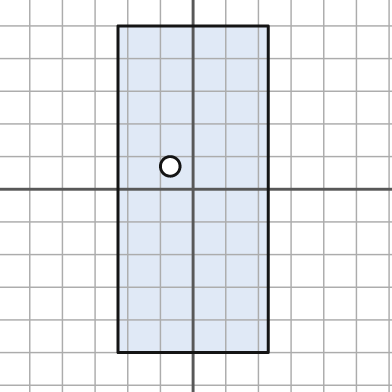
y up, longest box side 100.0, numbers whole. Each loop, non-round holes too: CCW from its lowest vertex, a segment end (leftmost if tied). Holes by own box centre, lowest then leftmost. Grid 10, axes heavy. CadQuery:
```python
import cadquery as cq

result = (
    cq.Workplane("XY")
    .moveTo(-23.0, -50.0)
    .lineTo(23.0, -50.0)
    .lineTo(23.0, 50.0)
    .lineTo(-23.0, 50.0)
    .close()
    .moveTo(-7.0, 7.0)
    .circle(3.0)
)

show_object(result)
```